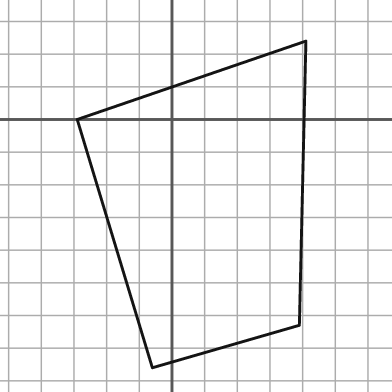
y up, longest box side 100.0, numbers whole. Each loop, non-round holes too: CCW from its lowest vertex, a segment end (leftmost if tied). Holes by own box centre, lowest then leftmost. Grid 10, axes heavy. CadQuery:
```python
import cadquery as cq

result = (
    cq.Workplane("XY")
    .moveTo(-6.0, -76.0)
    .lineTo(39.0, -63.0)
    .lineTo(41.0, 24.0)
    .lineTo(-29.0, 0.0)
    .close()
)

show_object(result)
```